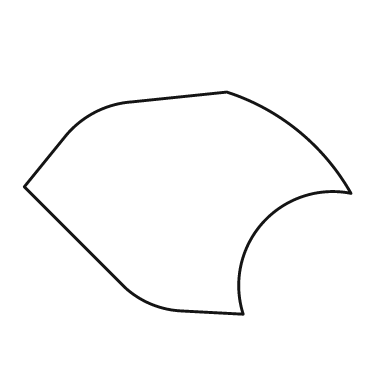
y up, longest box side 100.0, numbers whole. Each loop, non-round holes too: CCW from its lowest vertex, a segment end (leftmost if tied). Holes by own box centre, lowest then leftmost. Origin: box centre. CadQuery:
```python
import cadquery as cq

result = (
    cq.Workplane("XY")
    .moveTo(17.0, -34.0)
    .threePointArc((23.0, -6.0), (50.0, 3.0))
    .threePointArc((34.0, 22.0), (12.0, 34.0))
    .lineTo(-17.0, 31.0)
    .threePointArc((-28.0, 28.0), (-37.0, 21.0))
    .lineTo(-50.0, 5.0)
    .lineTo(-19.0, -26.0)
    .threePointArc((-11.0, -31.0), (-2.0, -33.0))
    .close()
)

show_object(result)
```